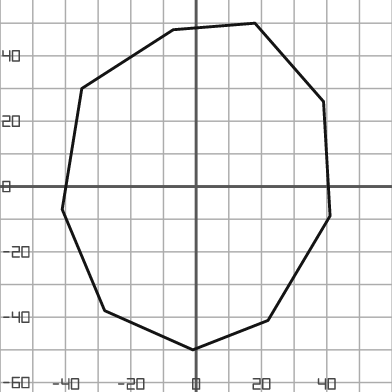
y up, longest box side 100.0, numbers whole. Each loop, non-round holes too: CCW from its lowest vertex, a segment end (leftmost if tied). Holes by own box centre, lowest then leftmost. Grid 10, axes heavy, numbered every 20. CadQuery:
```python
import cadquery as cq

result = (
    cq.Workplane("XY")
    .moveTo(-1.0, -50.0)
    .lineTo(22.0, -41.0)
    .lineTo(41.0, -9.0)
    .lineTo(39.0, 26.0)
    .lineTo(18.0, 50.0)
    .lineTo(-7.0, 48.0)
    .lineTo(-35.0, 30.0)
    .lineTo(-41.0, -7.0)
    .lineTo(-28.0, -38.0)
    .close()
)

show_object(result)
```